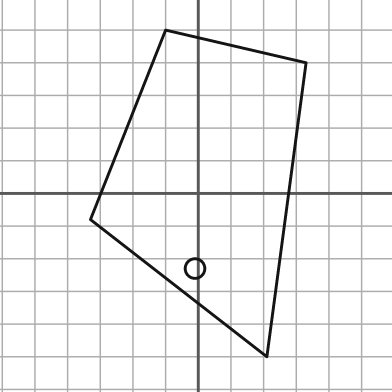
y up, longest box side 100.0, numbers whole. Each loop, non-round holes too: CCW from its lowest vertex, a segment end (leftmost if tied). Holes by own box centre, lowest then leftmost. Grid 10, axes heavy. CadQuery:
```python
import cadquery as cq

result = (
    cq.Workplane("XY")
    .moveTo(21.0, -50.0)
    .lineTo(33.0, 40.0)
    .lineTo(-10.0, 50.0)
    .lineTo(-33.0, -8.0)
    .close()
    .moveTo(-1.0, -23.0)
    .circle(3.0)
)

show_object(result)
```